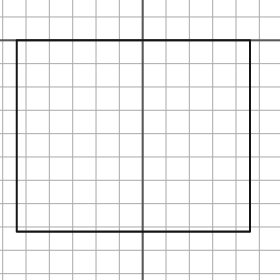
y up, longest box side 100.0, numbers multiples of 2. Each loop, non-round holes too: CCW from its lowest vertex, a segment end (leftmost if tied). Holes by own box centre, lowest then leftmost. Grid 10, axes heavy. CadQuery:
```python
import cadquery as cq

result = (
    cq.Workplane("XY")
    .moveTo(-54.0, -82.0)
    .lineTo(46.0, -82.0)
    .lineTo(46.0, 0.0)
    .lineTo(-54.0, 0.0)
    .close()
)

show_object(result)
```